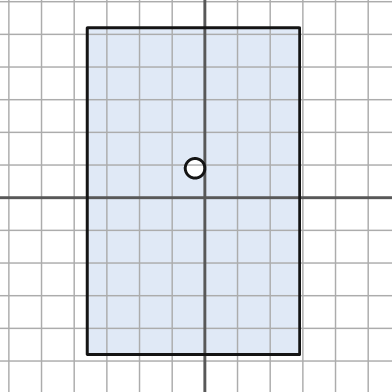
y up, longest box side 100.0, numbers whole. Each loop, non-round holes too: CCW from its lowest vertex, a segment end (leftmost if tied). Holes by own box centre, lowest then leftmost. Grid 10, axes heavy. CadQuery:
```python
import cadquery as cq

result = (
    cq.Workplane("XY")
    .moveTo(-36.0, -48.0)
    .lineTo(29.0, -48.0)
    .lineTo(29.0, 52.0)
    .lineTo(-36.0, 52.0)
    .close()
    .moveTo(-3.0, 9.0)
    .circle(3.0)
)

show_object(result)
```